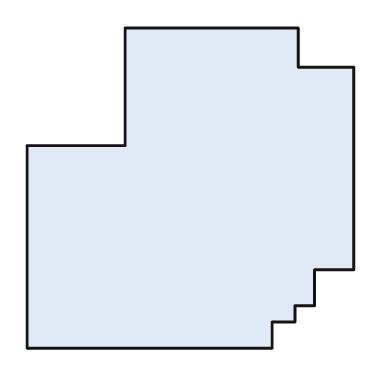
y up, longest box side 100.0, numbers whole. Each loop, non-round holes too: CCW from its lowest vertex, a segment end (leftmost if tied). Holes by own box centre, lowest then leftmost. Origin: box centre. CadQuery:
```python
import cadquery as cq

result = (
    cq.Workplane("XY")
    .moveTo(-50.0, -49.0)
    .lineTo(25.0, -49.0)
    .lineTo(25.0, -41.0)
    .lineTo(32.0, -41.0)
    .lineTo(32.0, -36.0)
    .lineTo(38.0, -36.0)
    .lineTo(38.0, -25.0)
    .lineTo(50.0, -25.0)
    .lineTo(50.0, 37.0)
    .lineTo(33.0, 37.0)
    .lineTo(33.0, 49.0)
    .lineTo(-20.0, 49.0)
    .lineTo(-20.0, 13.0)
    .lineTo(-50.0, 13.0)
    .close()
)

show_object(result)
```